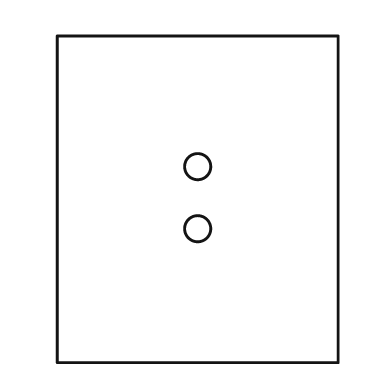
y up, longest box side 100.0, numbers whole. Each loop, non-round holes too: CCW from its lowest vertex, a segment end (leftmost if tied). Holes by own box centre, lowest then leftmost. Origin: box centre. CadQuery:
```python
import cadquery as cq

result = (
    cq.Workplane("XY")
    .moveTo(-43.0, -50.0)
    .lineTo(43.0, -50.0)
    .lineTo(43.0, 50.0)
    .lineTo(-43.0, 50.0)
    .close()
    .moveTo(0.0, -9.0)
    .circle(4.0)
    .moveTo(0.0, 10.0)
    .circle(4.0)
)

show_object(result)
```